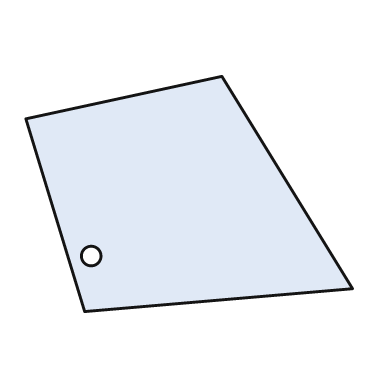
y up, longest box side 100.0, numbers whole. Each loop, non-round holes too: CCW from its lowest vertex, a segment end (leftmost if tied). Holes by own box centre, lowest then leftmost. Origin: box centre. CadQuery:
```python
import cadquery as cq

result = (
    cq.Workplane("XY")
    .moveTo(-32.0, -36.0)
    .lineTo(50.0, -29.0)
    .lineTo(10.0, 36.0)
    .lineTo(-50.0, 23.0)
    .close()
    .moveTo(-30.0, -19.0)
    .circle(3.0)
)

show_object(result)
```